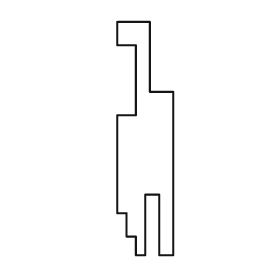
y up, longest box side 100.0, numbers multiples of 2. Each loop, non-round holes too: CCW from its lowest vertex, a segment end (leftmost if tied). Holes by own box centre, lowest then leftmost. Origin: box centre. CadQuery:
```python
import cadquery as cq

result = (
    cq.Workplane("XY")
    .moveTo(-4.0, -50.0)
    .lineTo(0.0, -50.0)
    .lineTo(0.0, -24.0)
    .lineTo(6.0, -24.0)
    .lineTo(6.0, -50.0)
    .lineTo(12.0, -50.0)
    .lineTo(12.0, 20.0)
    .lineTo(2.0, 20.0)
    .lineTo(2.0, 50.0)
    .lineTo(-12.0, 50.0)
    .lineTo(-12.0, 40.0)
    .lineTo(-4.0, 40.0)
    .lineTo(-4.0, 10.0)
    .lineTo(-12.0, 10.0)
    .lineTo(-12.0, -32.0)
    .lineTo(-8.0, -32.0)
    .lineTo(-8.0, -42.0)
    .lineTo(-4.0, -42.0)
    .close()
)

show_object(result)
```